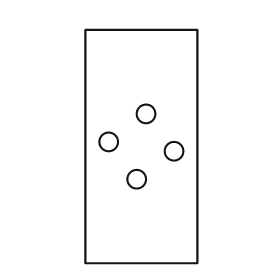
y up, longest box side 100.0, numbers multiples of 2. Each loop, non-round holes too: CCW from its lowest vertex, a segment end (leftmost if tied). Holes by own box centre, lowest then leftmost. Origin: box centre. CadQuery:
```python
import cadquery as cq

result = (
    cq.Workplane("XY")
    .moveTo(-24.0, -50.0)
    .lineTo(24.0, -50.0)
    .lineTo(24.0, 50.0)
    .lineTo(-24.0, 50.0)
    .close()
    .moveTo(-2.0, -14.0)
    .circle(4.0)
    .moveTo(14.0, -2.0)
    .circle(4.0)
    .moveTo(-14.0, 2.0)
    .circle(4.0)
    .moveTo(2.0, 14.0)
    .circle(4.0)
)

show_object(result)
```